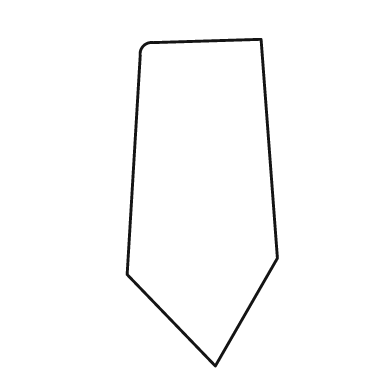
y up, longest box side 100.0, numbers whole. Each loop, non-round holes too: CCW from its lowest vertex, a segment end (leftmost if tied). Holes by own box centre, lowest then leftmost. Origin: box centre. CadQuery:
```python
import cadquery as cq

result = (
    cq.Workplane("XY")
    .moveTo(4.0, -50.0)
    .lineTo(23.0, -17.0)
    .lineTo(18.0, 50.0)
    .lineTo(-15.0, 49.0)
    .threePointArc((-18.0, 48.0), (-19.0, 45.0))
    .lineTo(-23.0, -22.0)
    .close()
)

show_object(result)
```